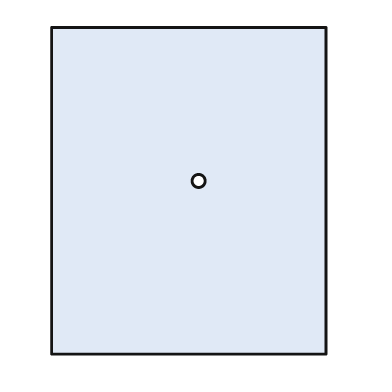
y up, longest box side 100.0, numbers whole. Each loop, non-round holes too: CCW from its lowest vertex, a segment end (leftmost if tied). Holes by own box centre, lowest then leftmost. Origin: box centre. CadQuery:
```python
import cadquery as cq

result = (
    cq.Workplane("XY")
    .moveTo(-42.0, -50.0)
    .lineTo(42.0, -50.0)
    .lineTo(42.0, 50.0)
    .lineTo(-42.0, 50.0)
    .close()
    .moveTo(3.0, 3.0)
    .circle(2.0)
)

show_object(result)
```